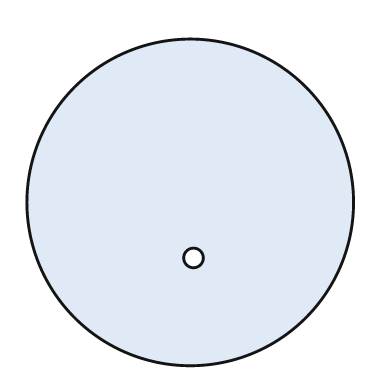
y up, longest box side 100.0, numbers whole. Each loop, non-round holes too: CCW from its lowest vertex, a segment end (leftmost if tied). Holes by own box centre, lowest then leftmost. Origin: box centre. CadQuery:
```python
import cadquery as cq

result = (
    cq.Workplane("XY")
    .moveTo(0.0, 0.0)
    .circle(50.0)
    .moveTo(1.0, -17.0)
    .circle(3.0)
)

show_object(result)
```